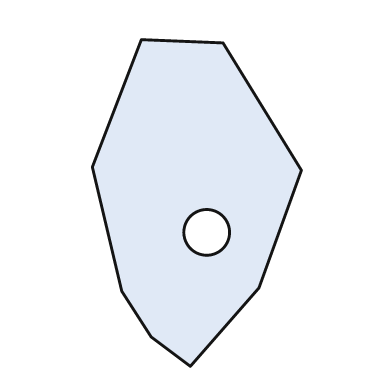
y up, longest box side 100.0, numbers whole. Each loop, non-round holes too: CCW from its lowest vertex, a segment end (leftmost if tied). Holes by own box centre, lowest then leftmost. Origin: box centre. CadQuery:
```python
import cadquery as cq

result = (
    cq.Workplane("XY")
    .moveTo(-2.0, -50.0)
    .lineTo(19.0, -26.0)
    .lineTo(32.0, 10.0)
    .lineTo(8.0, 49.0)
    .lineTo(-17.0, 50.0)
    .lineTo(-32.0, 11.0)
    .lineTo(-23.0, -27.0)
    .lineTo(-14.0, -41.0)
    .close()
    .moveTo(3.0, -9.0)
    .circle(7.0)
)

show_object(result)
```